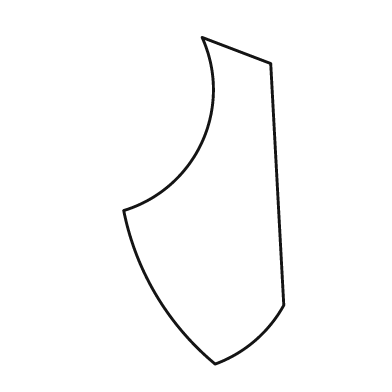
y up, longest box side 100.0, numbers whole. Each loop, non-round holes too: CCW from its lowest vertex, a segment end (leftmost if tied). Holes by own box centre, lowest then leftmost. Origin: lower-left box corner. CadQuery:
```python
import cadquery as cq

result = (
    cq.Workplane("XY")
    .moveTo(28.0, 0.0)
    .threePointArc((40.0, 7.0), (49.0, 18.0))
    .lineTo(45.0, 92.0)
    .lineTo(24.0, 100.0)
    .threePointArc((24.0, 68.0), (0.0, 47.0))
    .threePointArc((10.0, 21.0), (28.0, 0.0))
    .close()
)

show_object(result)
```